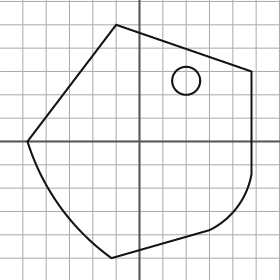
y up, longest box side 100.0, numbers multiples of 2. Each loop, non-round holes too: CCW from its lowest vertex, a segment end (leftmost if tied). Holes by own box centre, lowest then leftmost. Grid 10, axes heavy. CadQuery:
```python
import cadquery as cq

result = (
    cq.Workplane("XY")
    .moveTo(-12.0, -50.0)
    .lineTo(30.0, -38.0)
    .threePointArc((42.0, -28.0), (48.0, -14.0))
    .lineTo(48.0, 30.0)
    .lineTo(-10.0, 50.0)
    .lineTo(-48.0, 0.0)
    .threePointArc((-34.0, -28.0), (-12.0, -50.0))
    .close()
    .moveTo(20.0, 26.0)
    .circle(6.0)
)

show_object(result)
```